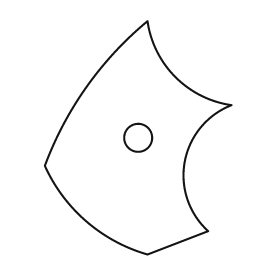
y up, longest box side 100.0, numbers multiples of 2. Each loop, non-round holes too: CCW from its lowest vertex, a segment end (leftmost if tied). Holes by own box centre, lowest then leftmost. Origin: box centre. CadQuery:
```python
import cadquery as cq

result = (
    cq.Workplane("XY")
    .moveTo(4.0, -50.0)
    .lineTo(30.0, -40.0)
    .threePointArc((20.0, -10.0), (40.0, 14.0))
    .threePointArc((16.0, 26.0), (4.0, 50.0))
    .threePointArc((-22.0, 22.0), (-40.0, -12.0))
    .threePointArc((-22.0, -36.0), (4.0, -50.0))
    .close()
    .moveTo(0.0, 0.0)
    .circle(6.0)
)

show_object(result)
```